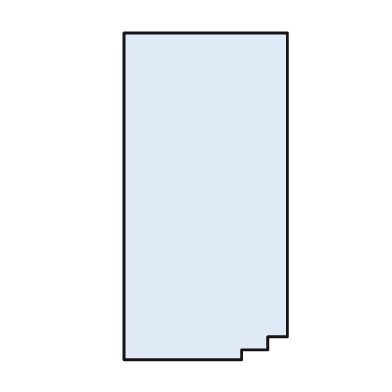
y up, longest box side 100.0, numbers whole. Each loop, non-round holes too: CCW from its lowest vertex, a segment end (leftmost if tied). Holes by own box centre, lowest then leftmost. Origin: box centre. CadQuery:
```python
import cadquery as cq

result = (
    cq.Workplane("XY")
    .moveTo(-25.0, -50.0)
    .lineTo(11.0, -50.0)
    .lineTo(11.0, -47.0)
    .lineTo(19.0, -47.0)
    .lineTo(19.0, -43.0)
    .lineTo(25.0, -43.0)
    .lineTo(25.0, 50.0)
    .lineTo(-25.0, 50.0)
    .close()
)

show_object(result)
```